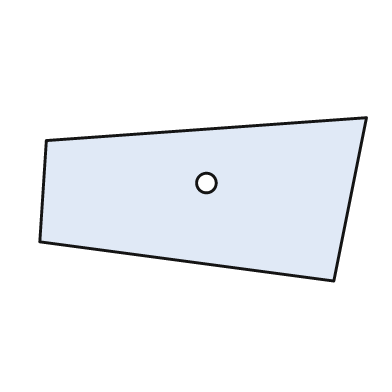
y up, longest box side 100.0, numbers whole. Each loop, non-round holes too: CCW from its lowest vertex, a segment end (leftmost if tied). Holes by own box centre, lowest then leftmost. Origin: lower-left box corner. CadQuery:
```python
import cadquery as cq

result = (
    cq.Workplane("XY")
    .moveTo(90.0, 0.0)
    .lineTo(100.0, 50.0)
    .lineTo(2.0, 43.0)
    .lineTo(0.0, 12.0)
    .close()
    .moveTo(51.0, 30.0)
    .circle(3.0)
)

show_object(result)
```